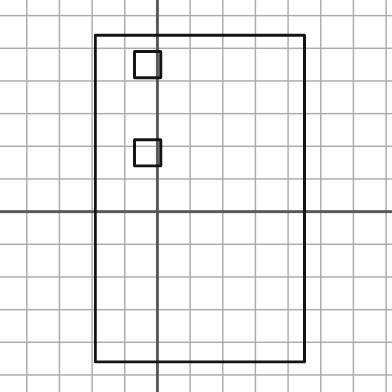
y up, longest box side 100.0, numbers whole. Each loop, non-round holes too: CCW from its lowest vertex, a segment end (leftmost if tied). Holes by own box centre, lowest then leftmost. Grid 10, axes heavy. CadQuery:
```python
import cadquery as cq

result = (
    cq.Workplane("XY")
    .moveTo(-19.0, -46.0)
    .lineTo(45.0, -46.0)
    .lineTo(45.0, 54.0)
    .lineTo(-19.0, 54.0)
    .close()
    .moveTo(-7.0, 14.0)
    .lineTo(1.0, 14.0)
    .lineTo(1.0, 22.0)
    .lineTo(-7.0, 22.0)
    .close()
    .moveTo(-7.0, 41.0)
    .lineTo(1.0, 41.0)
    .lineTo(1.0, 49.0)
    .lineTo(-7.0, 49.0)
    .close()
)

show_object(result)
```